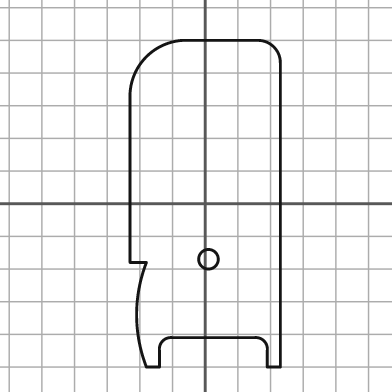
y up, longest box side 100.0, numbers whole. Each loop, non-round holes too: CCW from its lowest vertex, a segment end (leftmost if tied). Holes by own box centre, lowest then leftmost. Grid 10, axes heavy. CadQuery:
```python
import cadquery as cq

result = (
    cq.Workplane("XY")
    .moveTo(-18.0, -50.0)
    .lineTo(-14.0, -50.0)
    .lineTo(-14.0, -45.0)
    .threePointArc((-13.0, -42.0), (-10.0, -41.0))
    .lineTo(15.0, -41.0)
    .threePointArc((18.0, -42.0), (19.0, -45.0))
    .lineTo(19.0, -50.0)
    .lineTo(23.0, -50.0)
    .lineTo(23.0, 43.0)
    .threePointArc((21.0, 48.0), (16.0, 50.0))
    .lineTo(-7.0, 50.0)
    .threePointArc((-18.0, 45.0), (-23.0, 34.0))
    .lineTo(-23.0, -18.0)
    .lineTo(-18.0, -18.0)
    .threePointArc((-21.0, -34.0), (-18.0, -50.0))
    .close()
    .moveTo(1.0, -17.0)
    .circle(3.0)
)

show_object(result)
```